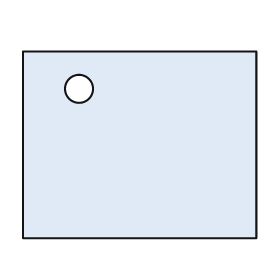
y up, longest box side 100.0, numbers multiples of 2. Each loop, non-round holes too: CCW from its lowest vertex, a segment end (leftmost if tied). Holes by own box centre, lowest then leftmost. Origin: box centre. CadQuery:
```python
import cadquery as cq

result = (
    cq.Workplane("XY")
    .moveTo(-50.0, -40.0)
    .lineTo(50.0, -40.0)
    .lineTo(50.0, 40.0)
    .lineTo(-50.0, 40.0)
    .close()
    .moveTo(-26.0, 24.0)
    .circle(6.0)
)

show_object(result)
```